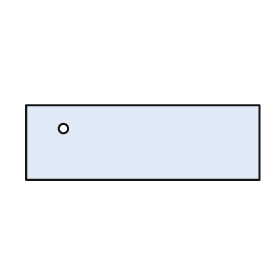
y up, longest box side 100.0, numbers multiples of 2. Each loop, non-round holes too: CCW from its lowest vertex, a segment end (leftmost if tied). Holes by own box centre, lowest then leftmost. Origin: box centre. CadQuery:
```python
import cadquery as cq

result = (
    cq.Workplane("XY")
    .moveTo(-50.0, -16.0)
    .lineTo(50.0, -16.0)
    .lineTo(50.0, 16.0)
    .lineTo(-50.0, 16.0)
    .close()
    .moveTo(-34.0, 6.0)
    .circle(2.0)
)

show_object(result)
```